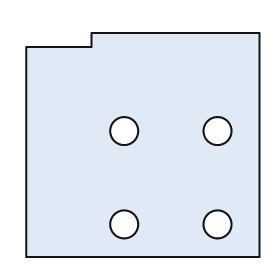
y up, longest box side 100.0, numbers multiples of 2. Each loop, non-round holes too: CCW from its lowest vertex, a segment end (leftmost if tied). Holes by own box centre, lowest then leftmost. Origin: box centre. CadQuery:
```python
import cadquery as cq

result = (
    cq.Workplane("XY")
    .moveTo(-50.0, -48.0)
    .lineTo(50.0, -48.0)
    .lineTo(50.0, 48.0)
    .lineTo(-22.0, 48.0)
    .lineTo(-22.0, 42.0)
    .lineTo(-50.0, 42.0)
    .close()
    .moveTo(-8.0, -34.0)
    .circle(6.0)
    .moveTo(32.0, -34.0)
    .circle(6.0)
    .moveTo(-8.0, 6.0)
    .circle(6.0)
    .moveTo(32.0, 6.0)
    .circle(6.0)
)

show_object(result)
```